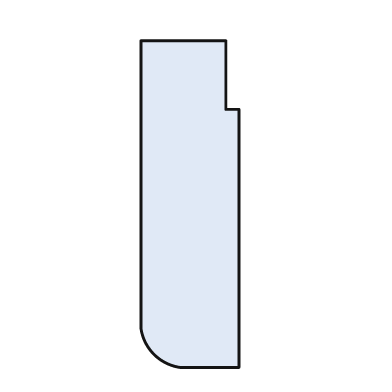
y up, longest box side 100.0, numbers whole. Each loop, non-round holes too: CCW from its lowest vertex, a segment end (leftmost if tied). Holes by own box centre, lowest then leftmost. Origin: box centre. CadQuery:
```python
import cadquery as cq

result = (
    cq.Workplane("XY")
    .moveTo(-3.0, -50.0)
    .lineTo(15.0, -50.0)
    .lineTo(15.0, 29.0)
    .lineTo(11.0, 29.0)
    .lineTo(11.0, 50.0)
    .lineTo(-15.0, 50.0)
    .lineTo(-15.0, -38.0)
    .threePointArc((-11.0, -46.0), (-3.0, -50.0))
    .close()
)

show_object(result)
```